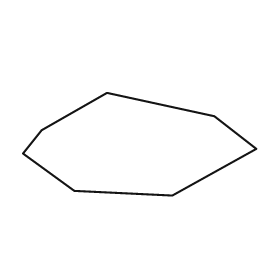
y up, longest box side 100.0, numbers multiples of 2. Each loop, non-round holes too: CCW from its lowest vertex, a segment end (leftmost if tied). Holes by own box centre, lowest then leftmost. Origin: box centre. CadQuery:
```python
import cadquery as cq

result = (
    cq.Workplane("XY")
    .moveTo(14.0, -22.0)
    .lineTo(50.0, -2.0)
    .lineTo(32.0, 12.0)
    .lineTo(-14.0, 22.0)
    .lineTo(-42.0, 6.0)
    .lineTo(-50.0, -4.0)
    .lineTo(-28.0, -20.0)
    .close()
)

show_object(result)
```